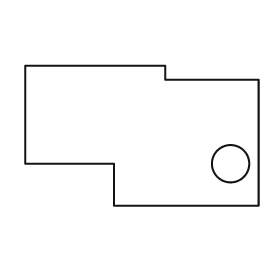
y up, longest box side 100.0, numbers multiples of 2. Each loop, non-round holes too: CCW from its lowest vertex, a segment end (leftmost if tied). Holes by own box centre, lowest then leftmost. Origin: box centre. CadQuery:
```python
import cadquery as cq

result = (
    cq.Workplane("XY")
    .moveTo(-12.0, -30.0)
    .lineTo(50.0, -30.0)
    .lineTo(50.0, 24.0)
    .lineTo(10.0, 24.0)
    .lineTo(10.0, 30.0)
    .lineTo(-50.0, 30.0)
    .lineTo(-50.0, -12.0)
    .lineTo(-12.0, -12.0)
    .close()
    .moveTo(38.0, -12.0)
    .circle(8.0)
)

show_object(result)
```